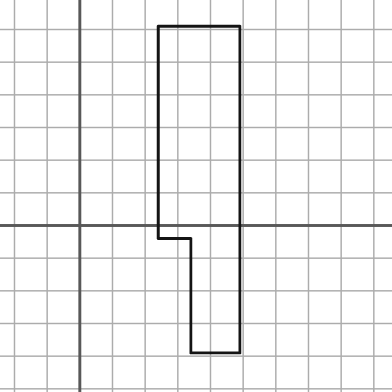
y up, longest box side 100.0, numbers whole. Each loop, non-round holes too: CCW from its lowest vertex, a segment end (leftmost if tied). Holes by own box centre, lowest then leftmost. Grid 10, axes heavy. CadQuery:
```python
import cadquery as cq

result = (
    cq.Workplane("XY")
    .moveTo(34.0, -39.0)
    .lineTo(49.0, -39.0)
    .lineTo(49.0, 61.0)
    .lineTo(24.0, 61.0)
    .lineTo(24.0, -4.0)
    .lineTo(34.0, -4.0)
    .close()
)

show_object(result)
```